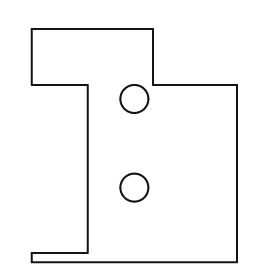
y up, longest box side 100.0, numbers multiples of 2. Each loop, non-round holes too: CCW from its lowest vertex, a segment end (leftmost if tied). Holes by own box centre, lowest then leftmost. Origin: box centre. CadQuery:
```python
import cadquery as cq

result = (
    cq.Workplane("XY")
    .moveTo(-44.0, -50.0)
    .lineTo(44.0, -50.0)
    .lineTo(44.0, 26.0)
    .lineTo(8.0, 26.0)
    .lineTo(8.0, 50.0)
    .lineTo(-44.0, 50.0)
    .lineTo(-44.0, 26.0)
    .lineTo(-20.0, 26.0)
    .lineTo(-20.0, -46.0)
    .lineTo(-44.0, -46.0)
    .close()
    .moveTo(0.0, -18.0)
    .circle(6.0)
    .moveTo(0.0, 20.0)
    .circle(6.0)
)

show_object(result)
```